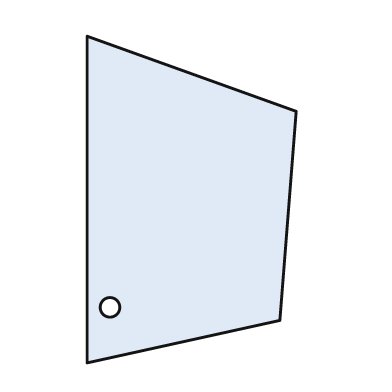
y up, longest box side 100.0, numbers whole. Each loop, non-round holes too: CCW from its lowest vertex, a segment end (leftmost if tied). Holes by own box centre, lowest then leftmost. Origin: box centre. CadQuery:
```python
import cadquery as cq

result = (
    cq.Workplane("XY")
    .moveTo(-32.0, -50.0)
    .lineTo(27.0, -37.0)
    .lineTo(32.0, 27.0)
    .lineTo(-32.0, 50.0)
    .close()
    .moveTo(-25.0, -33.0)
    .circle(3.0)
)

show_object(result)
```